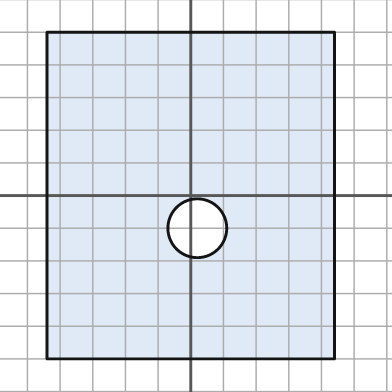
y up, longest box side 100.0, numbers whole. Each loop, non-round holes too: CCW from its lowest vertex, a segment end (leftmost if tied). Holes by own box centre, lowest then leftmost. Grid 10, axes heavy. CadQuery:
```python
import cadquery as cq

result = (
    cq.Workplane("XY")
    .moveTo(-44.0, -50.0)
    .lineTo(44.0, -50.0)
    .lineTo(44.0, 50.0)
    .lineTo(-44.0, 50.0)
    .close()
    .moveTo(2.0, -10.0)
    .circle(9.0)
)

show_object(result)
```